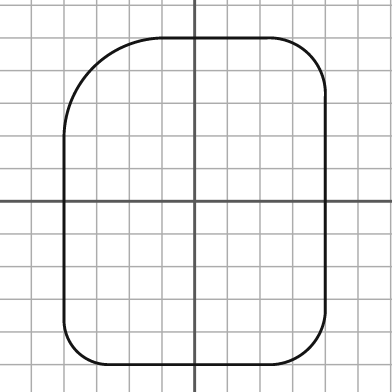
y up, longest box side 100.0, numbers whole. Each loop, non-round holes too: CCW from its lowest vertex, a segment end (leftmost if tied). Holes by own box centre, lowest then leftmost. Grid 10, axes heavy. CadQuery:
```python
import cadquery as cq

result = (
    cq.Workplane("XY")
    .moveTo(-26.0, -50.0)
    .lineTo(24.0, -50.0)
    .threePointArc((35.0, -45.0), (40.0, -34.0))
    .lineTo(40.0, 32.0)
    .threePointArc((35.0, 45.0), (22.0, 50.0))
    .lineTo(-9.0, 50.0)
    .threePointArc((-31.0, 41.0), (-40.0, 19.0))
    .lineTo(-40.0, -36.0)
    .threePointArc((-36.0, -46.0), (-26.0, -50.0))
    .close()
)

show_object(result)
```